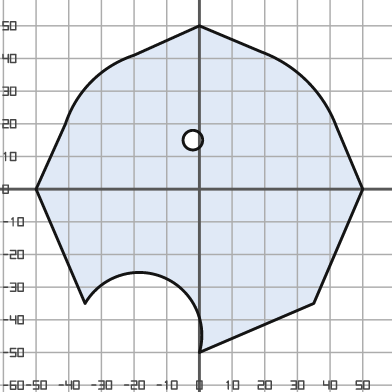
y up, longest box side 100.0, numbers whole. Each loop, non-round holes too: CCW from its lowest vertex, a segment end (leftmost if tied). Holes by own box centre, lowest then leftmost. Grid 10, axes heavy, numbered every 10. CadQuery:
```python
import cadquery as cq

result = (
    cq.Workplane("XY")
    .moveTo(0.0, -50.0)
    .lineTo(35.0, -35.0)
    .lineTo(50.0, 0.0)
    .lineTo(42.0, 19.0)
    .threePointArc((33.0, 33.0), (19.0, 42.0))
    .lineTo(0.0, 50.0)
    .lineTo(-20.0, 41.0)
    .threePointArc((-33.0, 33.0), (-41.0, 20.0))
    .lineTo(-50.0, 0.0)
    .lineTo(-35.0, -35.0)
    .threePointArc((-11.0, -27.0), (0.0, -50.0))
    .close()
    .moveTo(-2.0, 15.0)
    .circle(3.0)
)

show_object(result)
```